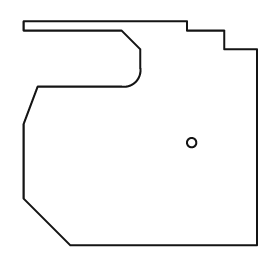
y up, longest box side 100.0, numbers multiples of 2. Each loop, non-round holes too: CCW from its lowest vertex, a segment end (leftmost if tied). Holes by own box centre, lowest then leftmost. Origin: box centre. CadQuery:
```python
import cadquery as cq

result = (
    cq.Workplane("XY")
    .moveTo(-30.0, -48.0)
    .lineTo(50.0, -48.0)
    .lineTo(50.0, 36.0)
    .lineTo(36.0, 36.0)
    .lineTo(36.0, 44.0)
    .lineTo(20.0, 44.0)
    .lineTo(20.0, 48.0)
    .lineTo(-50.0, 48.0)
    .lineTo(-50.0, 44.0)
    .lineTo(-8.0, 44.0)
    .lineTo(0.0, 36.0)
    .lineTo(0.0, 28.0)
    .threePointArc((-2.0, 22.0), (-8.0, 20.0))
    .lineTo(-44.0, 20.0)
    .lineTo(-50.0, 4.0)
    .lineTo(-50.0, -28.0)
    .close()
    .moveTo(22.0, -4.0)
    .circle(2.0)
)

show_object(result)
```